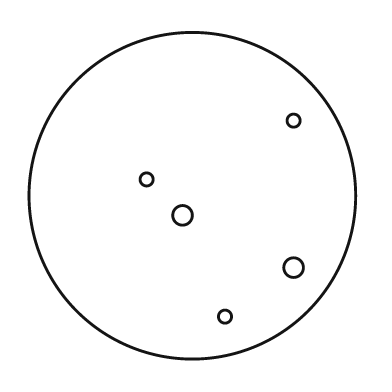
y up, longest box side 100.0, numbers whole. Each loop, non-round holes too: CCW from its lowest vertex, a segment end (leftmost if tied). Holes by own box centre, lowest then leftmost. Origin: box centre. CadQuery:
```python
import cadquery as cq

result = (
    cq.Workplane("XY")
    .moveTo(0.0, 0.0)
    .circle(50.0)
    .moveTo(10.0, -37.0)
    .circle(2.0)
    .moveTo(31.0, -22.0)
    .circle(3.0)
    .moveTo(-3.0, -6.0)
    .circle(3.0)
    .moveTo(-14.0, 5.0)
    .circle(2.0)
    .moveTo(31.0, 23.0)
    .circle(2.0)
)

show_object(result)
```